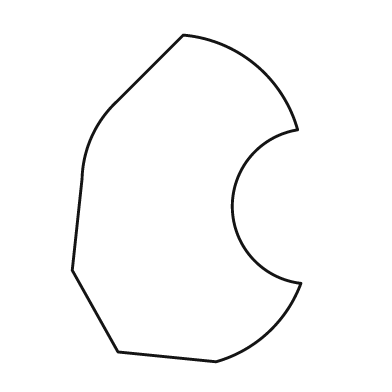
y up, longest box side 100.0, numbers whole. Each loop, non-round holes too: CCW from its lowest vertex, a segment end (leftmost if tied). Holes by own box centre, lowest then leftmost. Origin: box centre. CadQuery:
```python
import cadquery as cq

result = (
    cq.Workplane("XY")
    .moveTo(9.0, -50.0)
    .threePointArc((25.0, -41.0), (35.0, -26.0))
    .threePointArc((14.0, -3.0), (34.0, 21.0))
    .threePointArc((21.0, 41.0), (-1.0, 50.0))
    .lineTo(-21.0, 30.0)
    .threePointArc((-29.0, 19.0), (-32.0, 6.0))
    .lineTo(-35.0, -22.0)
    .lineTo(-21.0, -47.0)
    .close()
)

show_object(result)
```